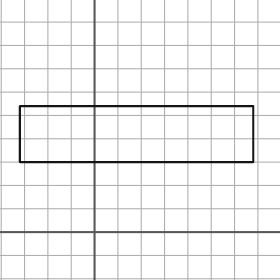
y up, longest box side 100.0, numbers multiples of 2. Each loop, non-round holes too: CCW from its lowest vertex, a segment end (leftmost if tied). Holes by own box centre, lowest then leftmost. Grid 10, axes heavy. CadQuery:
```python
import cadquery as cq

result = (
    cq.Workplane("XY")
    .moveTo(-32.0, 30.0)
    .lineTo(68.0, 30.0)
    .lineTo(68.0, 54.0)
    .lineTo(-32.0, 54.0)
    .close()
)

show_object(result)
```